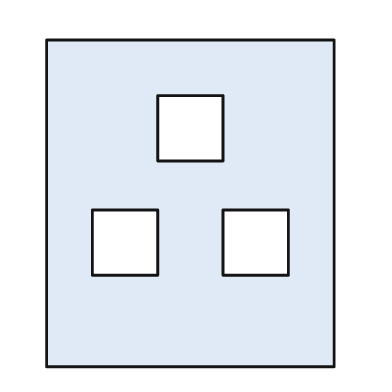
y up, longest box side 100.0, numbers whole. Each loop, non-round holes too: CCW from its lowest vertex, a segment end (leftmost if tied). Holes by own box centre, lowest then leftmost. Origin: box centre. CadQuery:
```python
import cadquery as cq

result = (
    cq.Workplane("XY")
    .moveTo(-44.0, -50.0)
    .lineTo(44.0, -50.0)
    .lineTo(44.0, 50.0)
    .lineTo(-44.0, 50.0)
    .close()
    .moveTo(-30.0, -22.0)
    .lineTo(-10.0, -22.0)
    .lineTo(-10.0, -2.0)
    .lineTo(-30.0, -2.0)
    .close()
    .moveTo(10.0, -22.0)
    .lineTo(30.0, -22.0)
    .lineTo(30.0, -2.0)
    .lineTo(10.0, -2.0)
    .close()
    .moveTo(-10.0, 13.0)
    .lineTo(10.0, 13.0)
    .lineTo(10.0, 33.0)
    .lineTo(-10.0, 33.0)
    .close()
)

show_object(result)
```